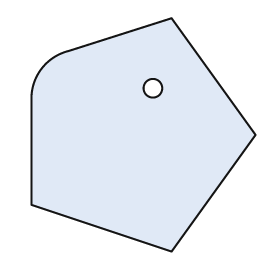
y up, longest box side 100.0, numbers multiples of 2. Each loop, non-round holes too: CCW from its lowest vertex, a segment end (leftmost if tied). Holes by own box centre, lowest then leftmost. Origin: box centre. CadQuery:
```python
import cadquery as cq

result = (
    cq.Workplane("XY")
    .moveTo(12.0, -50.0)
    .lineTo(48.0, 0.0)
    .lineTo(12.0, 50.0)
    .lineTo(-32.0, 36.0)
    .threePointArc((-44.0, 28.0), (-48.0, 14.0))
    .lineTo(-48.0, -30.0)
    .close()
    .moveTo(4.0, 20.0)
    .circle(4.0)
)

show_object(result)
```